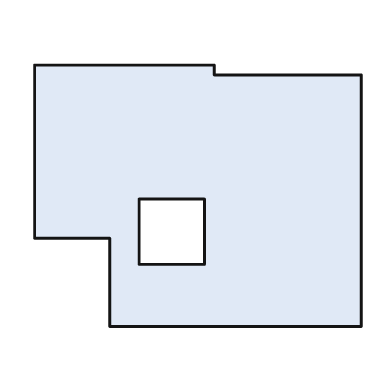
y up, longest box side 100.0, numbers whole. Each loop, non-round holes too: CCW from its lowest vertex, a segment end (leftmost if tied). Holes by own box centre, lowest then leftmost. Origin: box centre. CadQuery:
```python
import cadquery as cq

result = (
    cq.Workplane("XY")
    .moveTo(-27.0, -40.0)
    .lineTo(50.0, -40.0)
    .lineTo(50.0, 37.0)
    .lineTo(5.0, 37.0)
    .lineTo(5.0, 40.0)
    .lineTo(-50.0, 40.0)
    .lineTo(-50.0, -13.0)
    .lineTo(-27.0, -13.0)
    .close()
    .moveTo(-18.0, -21.0)
    .lineTo(2.0, -21.0)
    .lineTo(2.0, -1.0)
    .lineTo(-18.0, -1.0)
    .close()
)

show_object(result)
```